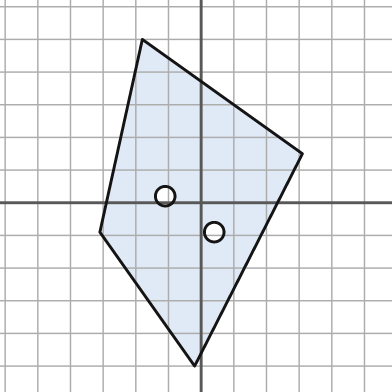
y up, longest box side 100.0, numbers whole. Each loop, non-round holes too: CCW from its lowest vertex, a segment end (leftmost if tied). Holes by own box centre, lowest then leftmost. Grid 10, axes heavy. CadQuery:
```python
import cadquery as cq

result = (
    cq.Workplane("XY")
    .moveTo(-2.0, -50.0)
    .lineTo(31.0, 15.0)
    .lineTo(-18.0, 50.0)
    .lineTo(-31.0, -9.0)
    .close()
    .moveTo(4.0, -9.0)
    .circle(3.0)
    .moveTo(-11.0, 2.0)
    .circle(3.0)
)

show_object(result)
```